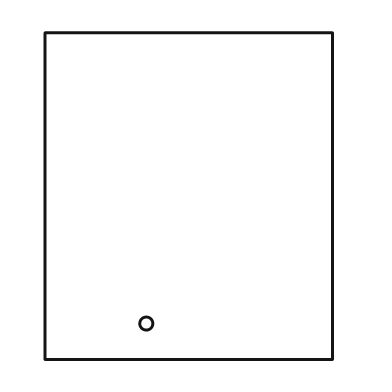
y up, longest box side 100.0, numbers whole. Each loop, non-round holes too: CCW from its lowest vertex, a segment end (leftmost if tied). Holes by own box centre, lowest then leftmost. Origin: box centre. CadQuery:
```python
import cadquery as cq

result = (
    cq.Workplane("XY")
    .moveTo(-44.0, -50.0)
    .lineTo(44.0, -50.0)
    .lineTo(44.0, 50.0)
    .lineTo(-44.0, 50.0)
    .close()
    .moveTo(-13.0, -39.0)
    .circle(2.0)
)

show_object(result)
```